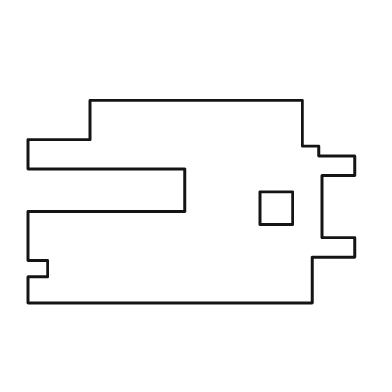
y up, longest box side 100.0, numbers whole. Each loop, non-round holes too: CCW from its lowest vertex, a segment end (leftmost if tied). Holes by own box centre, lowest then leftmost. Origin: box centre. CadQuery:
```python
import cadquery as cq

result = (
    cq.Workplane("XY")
    .moveTo(-50.0, -31.0)
    .lineTo(37.0, -31.0)
    .lineTo(37.0, -17.0)
    .lineTo(50.0, -17.0)
    .lineTo(50.0, -11.0)
    .lineTo(40.0, -11.0)
    .lineTo(40.0, 8.0)
    .lineTo(50.0, 8.0)
    .lineTo(50.0, 14.0)
    .lineTo(39.0, 14.0)
    .lineTo(39.0, 17.0)
    .lineTo(34.0, 17.0)
    .lineTo(34.0, 31.0)
    .lineTo(-31.0, 31.0)
    .lineTo(-31.0, 19.0)
    .lineTo(-50.0, 19.0)
    .lineTo(-50.0, 10.0)
    .lineTo(-2.0, 10.0)
    .lineTo(-2.0, -3.0)
    .lineTo(-50.0, -3.0)
    .lineTo(-50.0, -18.0)
    .lineTo(-44.0, -18.0)
    .lineTo(-44.0, -23.0)
    .lineTo(-50.0, -23.0)
    .close()
    .moveTo(21.0, -7.0)
    .lineTo(31.0, -7.0)
    .lineTo(31.0, 3.0)
    .lineTo(21.0, 3.0)
    .close()
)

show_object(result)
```